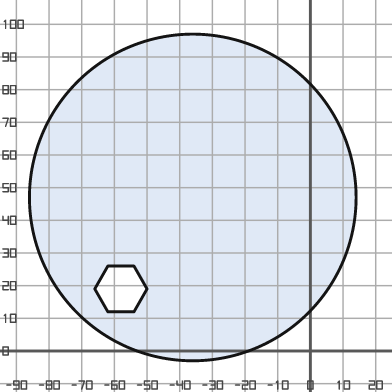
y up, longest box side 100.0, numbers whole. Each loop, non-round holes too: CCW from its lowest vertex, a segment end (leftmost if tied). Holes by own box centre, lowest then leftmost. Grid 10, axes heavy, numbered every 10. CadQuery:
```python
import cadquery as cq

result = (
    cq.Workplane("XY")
    .moveTo(-36.0, 47.0)
    .circle(50.0)
    .moveTo(-62.0, 12.0)
    .lineTo(-54.0, 12.0)
    .lineTo(-50.0, 19.0)
    .lineTo(-54.0, 26.0)
    .lineTo(-62.0, 26.0)
    .lineTo(-66.0, 19.0)
    .close()
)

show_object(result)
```